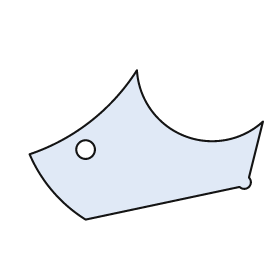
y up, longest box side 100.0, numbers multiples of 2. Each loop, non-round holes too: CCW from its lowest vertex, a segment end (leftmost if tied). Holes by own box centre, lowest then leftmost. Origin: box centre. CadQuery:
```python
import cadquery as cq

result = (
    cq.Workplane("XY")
    .moveTo(-26.0, -32.0)
    .lineTo(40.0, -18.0)
    .threePointArc((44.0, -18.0), (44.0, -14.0))
    .lineTo(50.0, 10.0)
    .threePointArc((16.0, 4.0), (-4.0, 32.0))
    .threePointArc((-24.0, 10.0), (-50.0, -4.0))
    .threePointArc((-40.0, -20.0), (-26.0, -32.0))
    .close()
    .moveTo(-26.0, -2.0)
    .circle(4.0)
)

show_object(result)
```